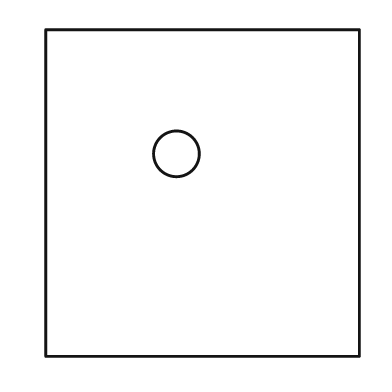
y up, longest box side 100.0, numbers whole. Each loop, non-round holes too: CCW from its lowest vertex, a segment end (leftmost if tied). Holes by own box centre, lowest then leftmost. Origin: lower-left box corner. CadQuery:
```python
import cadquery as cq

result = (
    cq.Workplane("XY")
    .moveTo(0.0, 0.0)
    .lineTo(96.0, 0.0)
    .lineTo(96.0, 100.0)
    .lineTo(0.0, 100.0)
    .close()
    .moveTo(40.0, 62.0)
    .circle(7.0)
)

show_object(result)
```